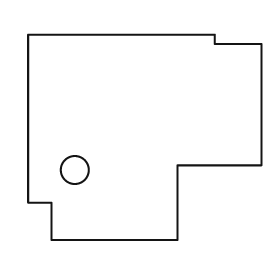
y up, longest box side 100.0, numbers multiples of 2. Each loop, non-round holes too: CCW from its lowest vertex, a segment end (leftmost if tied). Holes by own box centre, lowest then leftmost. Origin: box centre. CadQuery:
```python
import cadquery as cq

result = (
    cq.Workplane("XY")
    .moveTo(-40.0, -44.0)
    .lineTo(14.0, -44.0)
    .lineTo(14.0, -12.0)
    .lineTo(50.0, -12.0)
    .lineTo(50.0, 40.0)
    .lineTo(30.0, 40.0)
    .lineTo(30.0, 44.0)
    .lineTo(-50.0, 44.0)
    .lineTo(-50.0, -28.0)
    .lineTo(-40.0, -28.0)
    .close()
    .moveTo(-30.0, -14.0)
    .circle(6.0)
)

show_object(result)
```